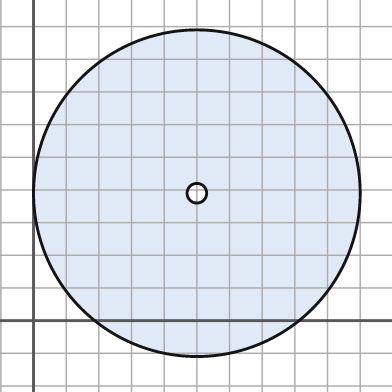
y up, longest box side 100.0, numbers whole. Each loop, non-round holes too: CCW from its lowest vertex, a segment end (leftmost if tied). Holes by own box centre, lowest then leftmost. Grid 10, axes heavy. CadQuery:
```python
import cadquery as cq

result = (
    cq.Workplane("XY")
    .moveTo(50.0, 39.0)
    .circle(50.0)
    .moveTo(50.0, 39.0)
    .circle(3.0)
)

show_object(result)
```